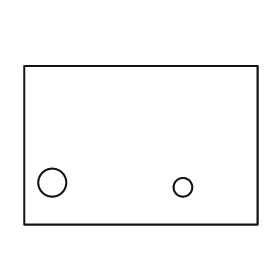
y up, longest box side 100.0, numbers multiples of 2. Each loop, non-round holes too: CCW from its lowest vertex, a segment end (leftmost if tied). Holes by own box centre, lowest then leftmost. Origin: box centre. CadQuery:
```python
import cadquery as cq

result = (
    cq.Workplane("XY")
    .moveTo(-50.0, -34.0)
    .lineTo(50.0, -34.0)
    .lineTo(50.0, 34.0)
    .lineTo(-50.0, 34.0)
    .close()
    .moveTo(18.0, -18.0)
    .circle(4.0)
    .moveTo(-38.0, -16.0)
    .circle(6.0)
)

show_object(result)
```